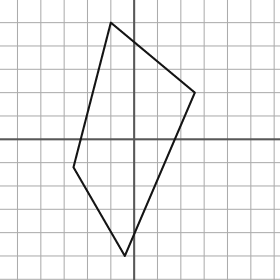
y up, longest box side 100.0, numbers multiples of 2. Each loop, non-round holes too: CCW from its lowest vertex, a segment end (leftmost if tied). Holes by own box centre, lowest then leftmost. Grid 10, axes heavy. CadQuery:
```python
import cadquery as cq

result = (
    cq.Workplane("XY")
    .moveTo(-4.0, -50.0)
    .lineTo(26.0, 20.0)
    .lineTo(-10.0, 50.0)
    .lineTo(-26.0, -12.0)
    .close()
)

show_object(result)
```